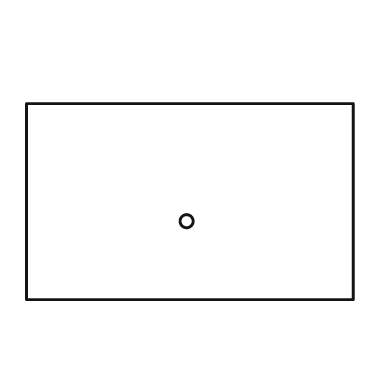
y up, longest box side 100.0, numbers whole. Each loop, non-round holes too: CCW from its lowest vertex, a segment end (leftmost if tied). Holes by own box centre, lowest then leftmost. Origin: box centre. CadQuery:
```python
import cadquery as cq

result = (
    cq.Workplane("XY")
    .moveTo(-50.0, -30.0)
    .lineTo(50.0, -30.0)
    .lineTo(50.0, 30.0)
    .lineTo(-50.0, 30.0)
    .close()
    .moveTo(-1.0, -6.0)
    .circle(2.0)
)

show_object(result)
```